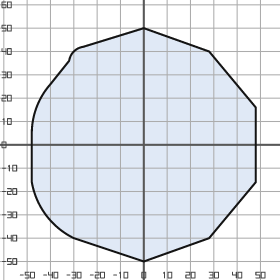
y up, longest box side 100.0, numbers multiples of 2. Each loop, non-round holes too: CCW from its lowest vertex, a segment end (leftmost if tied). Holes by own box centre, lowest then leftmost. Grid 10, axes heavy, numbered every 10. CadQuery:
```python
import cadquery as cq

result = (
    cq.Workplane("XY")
    .moveTo(0.0, -50.0)
    .lineTo(28.0, -40.0)
    .lineTo(48.0, -16.0)
    .lineTo(48.0, 16.0)
    .lineTo(28.0, 40.0)
    .lineTo(0.0, 50.0)
    .lineTo(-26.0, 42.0)
    .threePointArc((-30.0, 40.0), (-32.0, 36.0))
    .lineTo(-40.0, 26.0)
    .threePointArc((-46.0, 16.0), (-48.0, 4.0))
    .lineTo(-48.0, -16.0)
    .threePointArc((-42.0, -30.0), (-30.0, -40.0))
    .close()
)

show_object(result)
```